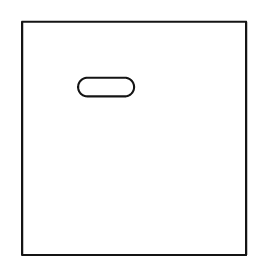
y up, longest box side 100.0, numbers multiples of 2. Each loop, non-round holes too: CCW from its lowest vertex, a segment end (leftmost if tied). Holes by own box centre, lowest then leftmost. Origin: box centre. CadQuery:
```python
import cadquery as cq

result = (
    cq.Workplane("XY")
    .moveTo(-48.0, -50.0)
    .lineTo(48.0, -50.0)
    .lineTo(48.0, 50.0)
    .lineTo(-48.0, 50.0)
    .close()
    .moveTo(-20.0, 18.0)
    .lineTo(-4.0, 18.0)
    .threePointArc((0.0, 22.0), (-4.0, 26.0))
    .lineTo(-20.0, 26.0)
    .threePointArc((-24.0, 22.0), (-20.0, 18.0))
    .close()
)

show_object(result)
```